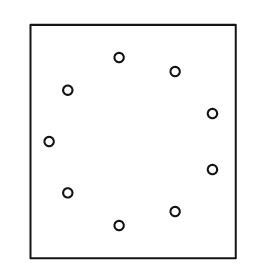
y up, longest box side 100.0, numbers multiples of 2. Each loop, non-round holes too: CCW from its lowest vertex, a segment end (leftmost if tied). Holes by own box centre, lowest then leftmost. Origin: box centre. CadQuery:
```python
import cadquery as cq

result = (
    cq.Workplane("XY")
    .moveTo(-44.0, -50.0)
    .lineTo(44.0, -50.0)
    .lineTo(44.0, 50.0)
    .lineTo(-44.0, 50.0)
    .close()
    .moveTo(-6.0, -36.0)
    .circle(2.0)
    .moveTo(18.0, -30.0)
    .circle(2.0)
    .moveTo(-28.0, -22.0)
    .circle(2.0)
    .moveTo(34.0, -12.0)
    .circle(2.0)
    .moveTo(-36.0, 0.0)
    .circle(2.0)
    .moveTo(34.0, 12.0)
    .circle(2.0)
    .moveTo(-28.0, 22.0)
    .circle(2.0)
    .moveTo(18.0, 30.0)
    .circle(2.0)
    .moveTo(-6.0, 36.0)
    .circle(2.0)
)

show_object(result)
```